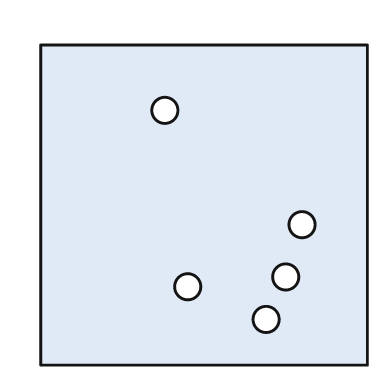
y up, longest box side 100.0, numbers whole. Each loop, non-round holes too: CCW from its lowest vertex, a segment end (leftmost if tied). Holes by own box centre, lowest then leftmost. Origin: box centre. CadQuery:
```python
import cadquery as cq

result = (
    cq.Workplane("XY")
    .moveTo(-50.0, -49.0)
    .lineTo(50.0, -49.0)
    .lineTo(50.0, 49.0)
    .lineTo(-50.0, 49.0)
    .close()
    .moveTo(19.0, -35.0)
    .circle(4.0)
    .moveTo(-5.0, -25.0)
    .circle(4.0)
    .moveTo(25.0, -22.0)
    .circle(4.0)
    .moveTo(30.0, -6.0)
    .circle(4.0)
    .moveTo(-12.0, 29.0)
    .circle(4.0)
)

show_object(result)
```